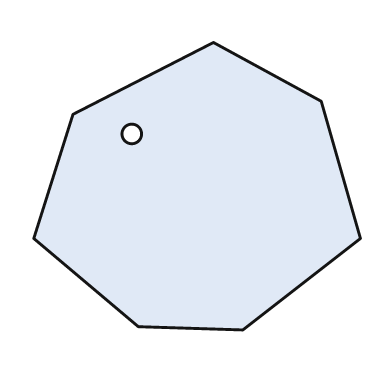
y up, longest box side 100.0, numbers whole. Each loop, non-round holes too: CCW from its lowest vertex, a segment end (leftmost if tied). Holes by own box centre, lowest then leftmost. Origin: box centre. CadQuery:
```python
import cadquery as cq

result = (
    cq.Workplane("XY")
    .moveTo(14.0, -44.0)
    .lineTo(50.0, -16.0)
    .lineTo(38.0, 26.0)
    .lineTo(5.0, 44.0)
    .lineTo(-38.0, 22.0)
    .lineTo(-50.0, -16.0)
    .lineTo(-18.0, -43.0)
    .close()
    .moveTo(-20.0, 16.0)
    .circle(3.0)
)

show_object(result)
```